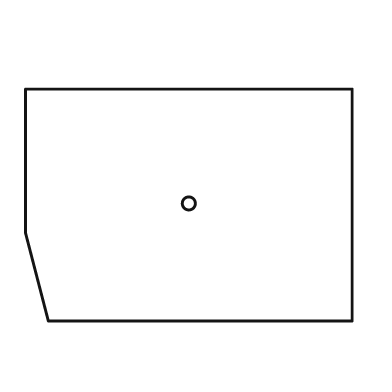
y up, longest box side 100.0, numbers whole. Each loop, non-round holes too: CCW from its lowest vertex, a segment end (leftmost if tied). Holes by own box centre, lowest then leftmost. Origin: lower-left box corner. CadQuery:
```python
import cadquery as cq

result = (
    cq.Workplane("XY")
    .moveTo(7.0, 0.0)
    .lineTo(100.0, 0.0)
    .lineTo(100.0, 71.0)
    .lineTo(0.0, 71.0)
    .lineTo(0.0, 27.0)
    .close()
    .moveTo(50.0, 36.0)
    .circle(2.0)
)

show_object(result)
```